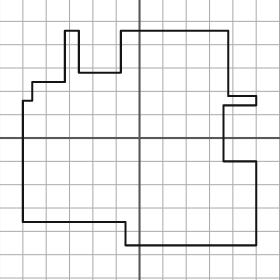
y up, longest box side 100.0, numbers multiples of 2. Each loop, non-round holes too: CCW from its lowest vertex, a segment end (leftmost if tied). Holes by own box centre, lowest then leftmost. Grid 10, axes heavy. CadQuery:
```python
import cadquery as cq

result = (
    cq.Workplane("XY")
    .moveTo(-6.0, -46.0)
    .lineTo(50.0, -46.0)
    .lineTo(50.0, -10.0)
    .lineTo(36.0, -10.0)
    .lineTo(36.0, 14.0)
    .lineTo(50.0, 14.0)
    .lineTo(50.0, 18.0)
    .lineTo(38.0, 18.0)
    .lineTo(38.0, 46.0)
    .lineTo(-8.0, 46.0)
    .lineTo(-8.0, 28.0)
    .lineTo(-26.0, 28.0)
    .lineTo(-26.0, 46.0)
    .lineTo(-32.0, 46.0)
    .lineTo(-32.0, 24.0)
    .lineTo(-46.0, 24.0)
    .lineTo(-46.0, 16.0)
    .lineTo(-50.0, 16.0)
    .lineTo(-50.0, -36.0)
    .lineTo(-6.0, -36.0)
    .close()
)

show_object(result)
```